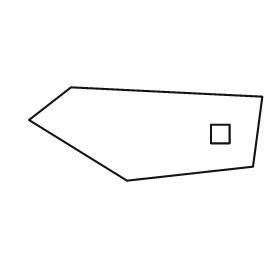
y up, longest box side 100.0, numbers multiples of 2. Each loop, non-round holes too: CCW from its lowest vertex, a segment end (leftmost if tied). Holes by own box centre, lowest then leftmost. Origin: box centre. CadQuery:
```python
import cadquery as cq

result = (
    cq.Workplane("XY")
    .moveTo(-8.0, -20.0)
    .lineTo(46.0, -14.0)
    .lineTo(50.0, 16.0)
    .lineTo(-32.0, 20.0)
    .lineTo(-50.0, 6.0)
    .close()
    .moveTo(28.0, -4.0)
    .lineTo(36.0, -4.0)
    .lineTo(36.0, 4.0)
    .lineTo(28.0, 4.0)
    .close()
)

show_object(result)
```